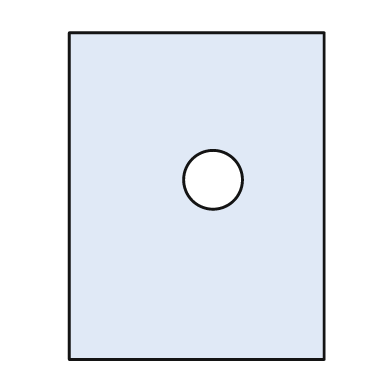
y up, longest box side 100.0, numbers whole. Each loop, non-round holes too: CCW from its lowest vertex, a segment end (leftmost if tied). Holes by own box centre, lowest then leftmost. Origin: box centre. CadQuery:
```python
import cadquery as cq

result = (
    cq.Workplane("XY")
    .moveTo(-39.0, -50.0)
    .lineTo(39.0, -50.0)
    .lineTo(39.0, 50.0)
    .lineTo(-39.0, 50.0)
    .close()
    .moveTo(5.0, 5.0)
    .circle(9.0)
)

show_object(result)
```